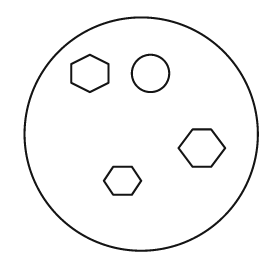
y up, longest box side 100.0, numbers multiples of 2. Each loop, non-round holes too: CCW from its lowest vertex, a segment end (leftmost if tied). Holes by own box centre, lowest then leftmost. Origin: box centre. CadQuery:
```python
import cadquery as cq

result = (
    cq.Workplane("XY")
    .moveTo(0.0, 0.0)
    .circle(50.0)
    .moveTo(-12.0, -26.0)
    .lineTo(-4.0, -26.0)
    .lineTo(0.0, -20.0)
    .lineTo(-4.0, -14.0)
    .lineTo(-12.0, -14.0)
    .lineTo(-16.0, -20.0)
    .close()
    .moveTo(22.0, -14.0)
    .lineTo(30.0, -14.0)
    .lineTo(36.0, -6.0)
    .lineTo(30.0, 2.0)
    .lineTo(22.0, 2.0)
    .lineTo(16.0, -6.0)
    .close()
    .moveTo(-22.0, 18.0)
    .lineTo(-14.0, 22.0)
    .lineTo(-14.0, 30.0)
    .lineTo(-22.0, 34.0)
    .lineTo(-30.0, 30.0)
    .lineTo(-30.0, 22.0)
    .close()
    .moveTo(4.0, 26.0)
    .circle(8.0)
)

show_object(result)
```